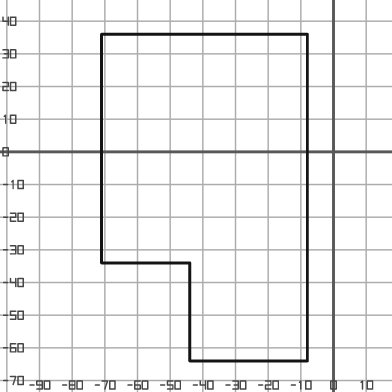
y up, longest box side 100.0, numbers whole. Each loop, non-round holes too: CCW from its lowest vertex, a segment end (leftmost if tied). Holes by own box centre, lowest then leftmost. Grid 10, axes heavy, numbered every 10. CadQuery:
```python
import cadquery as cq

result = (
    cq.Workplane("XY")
    .moveTo(-44.0, -64.0)
    .lineTo(-8.0, -64.0)
    .lineTo(-8.0, 36.0)
    .lineTo(-71.0, 36.0)
    .lineTo(-71.0, -34.0)
    .lineTo(-44.0, -34.0)
    .close()
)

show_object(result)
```